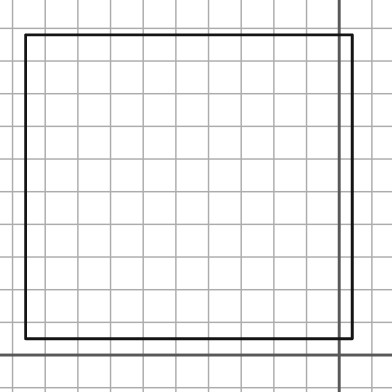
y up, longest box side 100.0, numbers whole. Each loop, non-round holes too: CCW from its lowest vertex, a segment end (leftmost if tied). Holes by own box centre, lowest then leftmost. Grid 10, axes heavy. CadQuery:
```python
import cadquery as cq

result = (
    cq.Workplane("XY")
    .moveTo(-96.0, 5.0)
    .lineTo(4.0, 5.0)
    .lineTo(4.0, 98.0)
    .lineTo(-96.0, 98.0)
    .close()
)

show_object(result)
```